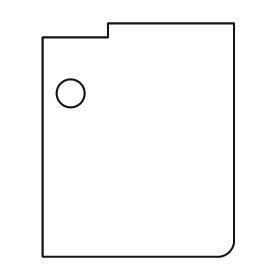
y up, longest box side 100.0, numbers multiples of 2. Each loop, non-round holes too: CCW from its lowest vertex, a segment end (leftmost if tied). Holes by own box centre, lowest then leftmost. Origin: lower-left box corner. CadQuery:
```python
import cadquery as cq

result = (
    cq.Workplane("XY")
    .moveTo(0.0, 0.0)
    .lineTo(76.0, 0.0)
    .threePointArc((80.0, 2.0), (82.0, 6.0))
    .lineTo(82.0, 100.0)
    .lineTo(28.0, 100.0)
    .lineTo(28.0, 94.0)
    .lineTo(0.0, 94.0)
    .close()
    .moveTo(12.0, 70.0)
    .circle(6.0)
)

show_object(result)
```